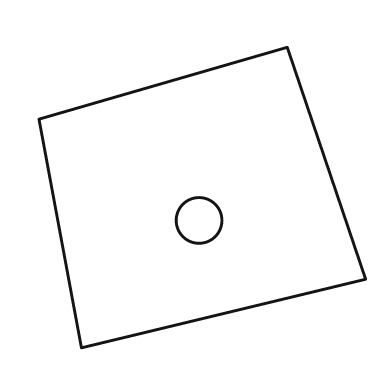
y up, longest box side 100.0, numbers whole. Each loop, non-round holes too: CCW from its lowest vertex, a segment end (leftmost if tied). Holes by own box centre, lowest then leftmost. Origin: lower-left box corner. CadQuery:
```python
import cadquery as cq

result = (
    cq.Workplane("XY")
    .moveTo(13.0, 0.0)
    .lineTo(100.0, 21.0)
    .lineTo(76.0, 92.0)
    .lineTo(0.0, 70.0)
    .close()
    .moveTo(49.0, 39.0)
    .circle(7.0)
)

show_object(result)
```